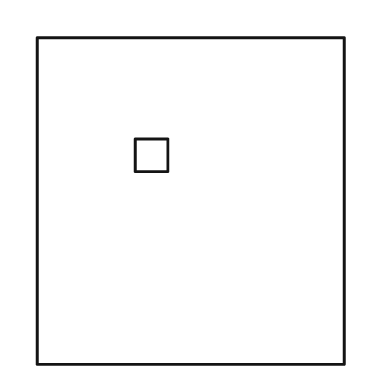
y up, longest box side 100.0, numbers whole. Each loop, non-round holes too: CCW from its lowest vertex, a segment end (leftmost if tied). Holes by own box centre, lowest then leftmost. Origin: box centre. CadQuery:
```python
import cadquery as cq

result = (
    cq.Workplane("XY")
    .moveTo(-47.0, -50.0)
    .lineTo(47.0, -50.0)
    .lineTo(47.0, 50.0)
    .lineTo(-47.0, 50.0)
    .close()
    .moveTo(-17.0, 9.0)
    .lineTo(-7.0, 9.0)
    .lineTo(-7.0, 19.0)
    .lineTo(-17.0, 19.0)
    .close()
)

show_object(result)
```